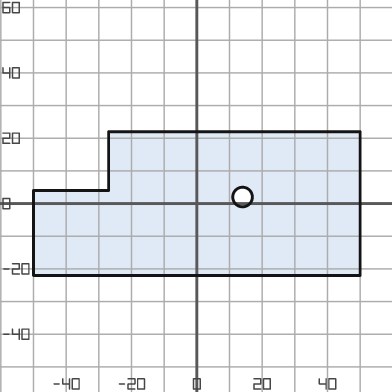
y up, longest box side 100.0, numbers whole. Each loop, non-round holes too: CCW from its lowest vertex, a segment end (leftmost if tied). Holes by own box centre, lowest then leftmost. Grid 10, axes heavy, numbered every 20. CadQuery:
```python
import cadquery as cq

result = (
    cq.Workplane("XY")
    .moveTo(-50.0, -22.0)
    .lineTo(50.0, -22.0)
    .lineTo(50.0, 22.0)
    .lineTo(-27.0, 22.0)
    .lineTo(-27.0, 4.0)
    .lineTo(-50.0, 4.0)
    .close()
    .moveTo(14.0, 2.0)
    .circle(3.0)
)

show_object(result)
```